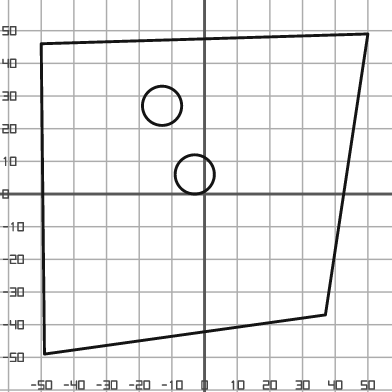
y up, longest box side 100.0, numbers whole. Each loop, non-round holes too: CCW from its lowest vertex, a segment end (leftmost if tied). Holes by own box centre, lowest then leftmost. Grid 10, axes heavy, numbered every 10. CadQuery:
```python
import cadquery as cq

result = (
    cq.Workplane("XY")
    .moveTo(-49.0, -49.0)
    .lineTo(37.0, -37.0)
    .lineTo(50.0, 49.0)
    .lineTo(-50.0, 46.0)
    .close()
    .moveTo(-3.0, 6.0)
    .circle(6.0)
    .moveTo(-13.0, 27.0)
    .circle(6.0)
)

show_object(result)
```